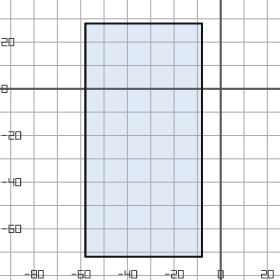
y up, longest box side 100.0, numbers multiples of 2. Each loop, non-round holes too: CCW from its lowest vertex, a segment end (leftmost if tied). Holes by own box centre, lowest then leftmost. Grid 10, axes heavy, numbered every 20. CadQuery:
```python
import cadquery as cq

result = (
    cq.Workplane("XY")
    .moveTo(-58.0, -72.0)
    .lineTo(-8.0, -72.0)
    .lineTo(-8.0, 28.0)
    .lineTo(-58.0, 28.0)
    .close()
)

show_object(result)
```